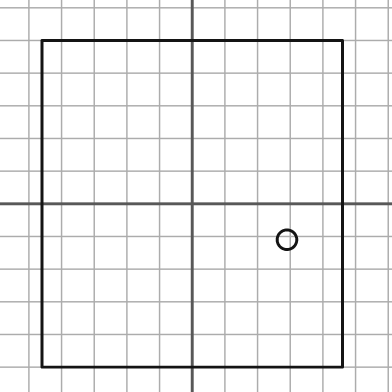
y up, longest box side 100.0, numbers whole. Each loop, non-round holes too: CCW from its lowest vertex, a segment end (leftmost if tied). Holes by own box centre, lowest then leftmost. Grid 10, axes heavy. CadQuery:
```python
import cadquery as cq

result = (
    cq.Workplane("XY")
    .moveTo(-46.0, -50.0)
    .lineTo(46.0, -50.0)
    .lineTo(46.0, 50.0)
    .lineTo(-46.0, 50.0)
    .close()
    .moveTo(29.0, -11.0)
    .circle(3.0)
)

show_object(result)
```